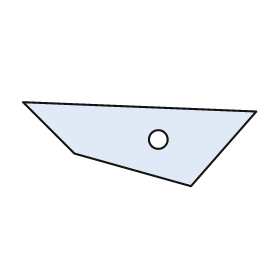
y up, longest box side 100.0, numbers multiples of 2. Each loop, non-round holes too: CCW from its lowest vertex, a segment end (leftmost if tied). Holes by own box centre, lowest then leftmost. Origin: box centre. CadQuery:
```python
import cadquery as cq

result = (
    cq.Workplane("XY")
    .moveTo(22.0, -18.0)
    .lineTo(50.0, 14.0)
    .lineTo(-50.0, 18.0)
    .lineTo(-28.0, -4.0)
    .close()
    .moveTo(8.0, 2.0)
    .circle(4.0)
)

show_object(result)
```